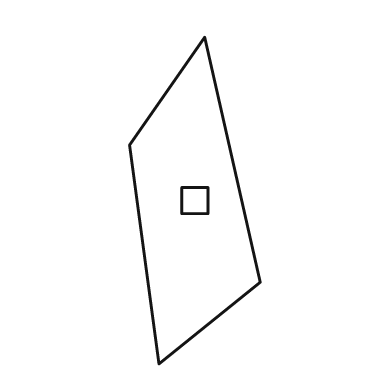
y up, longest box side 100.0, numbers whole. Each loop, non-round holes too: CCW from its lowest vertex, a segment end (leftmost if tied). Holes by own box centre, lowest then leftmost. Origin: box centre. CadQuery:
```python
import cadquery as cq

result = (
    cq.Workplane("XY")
    .moveTo(-11.0, -50.0)
    .lineTo(20.0, -25.0)
    .lineTo(3.0, 50.0)
    .lineTo(-20.0, 17.0)
    .close()
    .moveTo(-4.0, -4.0)
    .lineTo(4.0, -4.0)
    .lineTo(4.0, 4.0)
    .lineTo(-4.0, 4.0)
    .close()
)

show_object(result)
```